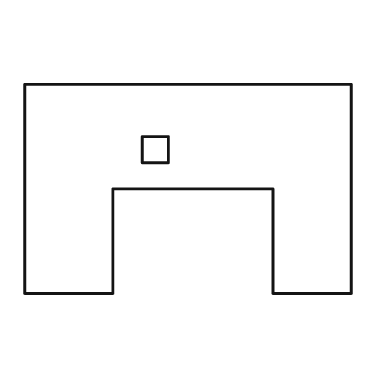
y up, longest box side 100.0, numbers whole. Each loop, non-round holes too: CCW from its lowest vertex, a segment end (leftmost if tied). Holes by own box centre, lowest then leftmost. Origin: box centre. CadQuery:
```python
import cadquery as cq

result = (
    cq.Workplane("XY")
    .moveTo(-50.0, -32.0)
    .lineTo(-23.0, -32.0)
    .lineTo(-23.0, 0.0)
    .lineTo(26.0, 0.0)
    .lineTo(26.0, -32.0)
    .lineTo(50.0, -32.0)
    .lineTo(50.0, 32.0)
    .lineTo(-50.0, 32.0)
    .close()
    .moveTo(-14.0, 8.0)
    .lineTo(-6.0, 8.0)
    .lineTo(-6.0, 16.0)
    .lineTo(-14.0, 16.0)
    .close()
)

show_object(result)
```